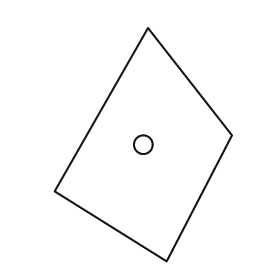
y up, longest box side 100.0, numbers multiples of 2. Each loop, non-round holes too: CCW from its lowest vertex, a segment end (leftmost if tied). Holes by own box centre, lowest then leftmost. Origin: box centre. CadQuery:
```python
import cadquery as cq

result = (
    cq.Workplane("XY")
    .moveTo(10.0, -50.0)
    .lineTo(38.0, 4.0)
    .lineTo(2.0, 50.0)
    .lineTo(-38.0, -20.0)
    .close()
    .moveTo(0.0, 0.0)
    .circle(4.0)
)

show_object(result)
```